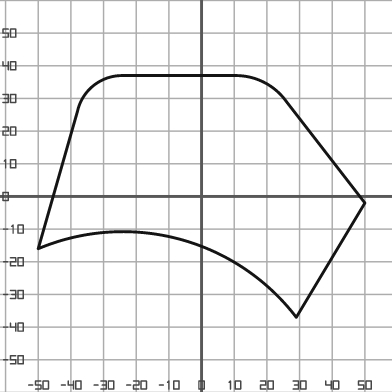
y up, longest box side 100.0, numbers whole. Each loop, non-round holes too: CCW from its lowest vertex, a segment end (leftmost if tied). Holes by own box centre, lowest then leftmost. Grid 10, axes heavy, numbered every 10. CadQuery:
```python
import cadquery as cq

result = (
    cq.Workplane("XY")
    .moveTo(29.0, -37.0)
    .lineTo(50.0, -2.0)
    .lineTo(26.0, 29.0)
    .threePointArc((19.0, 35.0), (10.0, 37.0))
    .lineTo(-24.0, 37.0)
    .threePointArc((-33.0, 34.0), (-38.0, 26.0))
    .lineTo(-50.0, -16.0)
    .threePointArc((-7.0, -13.0), (29.0, -37.0))
    .close()
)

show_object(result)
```